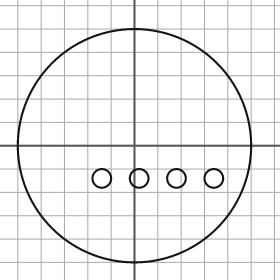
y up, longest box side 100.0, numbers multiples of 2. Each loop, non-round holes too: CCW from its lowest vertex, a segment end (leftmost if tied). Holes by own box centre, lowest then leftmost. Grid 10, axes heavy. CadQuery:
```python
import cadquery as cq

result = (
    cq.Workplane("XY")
    .moveTo(0.0, 0.0)
    .circle(50.0)
    .moveTo(-14.0, -14.0)
    .circle(4.0)
    .moveTo(2.0, -14.0)
    .circle(4.0)
    .moveTo(18.0, -14.0)
    .circle(4.0)
    .moveTo(34.0, -14.0)
    .circle(4.0)
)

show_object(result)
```